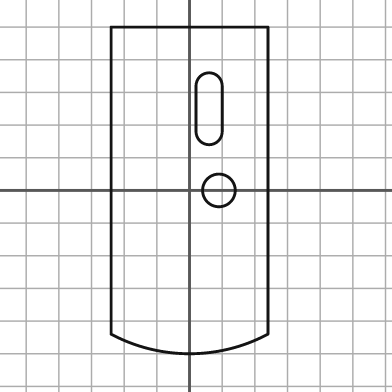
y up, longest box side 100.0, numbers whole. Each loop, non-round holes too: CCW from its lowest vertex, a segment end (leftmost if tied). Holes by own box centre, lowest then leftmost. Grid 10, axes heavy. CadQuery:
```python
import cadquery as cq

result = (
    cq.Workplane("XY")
    .moveTo(-24.0, -44.0)
    .threePointArc((0.0, -50.0), (24.0, -44.0))
    .lineTo(24.0, 50.0)
    .lineTo(-24.0, 50.0)
    .close()
    .moveTo(9.0, 0.0)
    .circle(5.0)
    .moveTo(2.0, 18.0)
    .threePointArc((6.0, 14.0), (10.0, 18.0))
    .lineTo(10.0, 32.0)
    .threePointArc((6.0, 36.0), (2.0, 32.0))
    .close()
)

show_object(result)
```